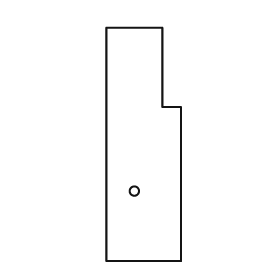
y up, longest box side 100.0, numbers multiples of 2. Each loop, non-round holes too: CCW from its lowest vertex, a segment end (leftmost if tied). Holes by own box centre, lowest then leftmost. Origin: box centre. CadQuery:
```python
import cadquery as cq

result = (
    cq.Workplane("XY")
    .moveTo(-16.0, -50.0)
    .lineTo(16.0, -50.0)
    .lineTo(16.0, 16.0)
    .lineTo(8.0, 16.0)
    .lineTo(8.0, 50.0)
    .lineTo(-16.0, 50.0)
    .close()
    .moveTo(-4.0, -20.0)
    .circle(2.0)
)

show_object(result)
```